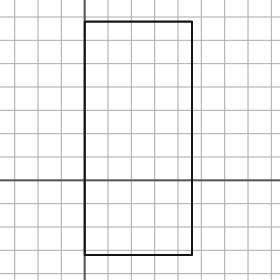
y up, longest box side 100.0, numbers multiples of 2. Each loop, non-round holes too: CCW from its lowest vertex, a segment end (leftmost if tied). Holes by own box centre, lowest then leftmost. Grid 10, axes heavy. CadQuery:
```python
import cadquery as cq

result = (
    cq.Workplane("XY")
    .moveTo(0.0, -32.0)
    .lineTo(46.0, -32.0)
    .lineTo(46.0, 68.0)
    .lineTo(0.0, 68.0)
    .close()
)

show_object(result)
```